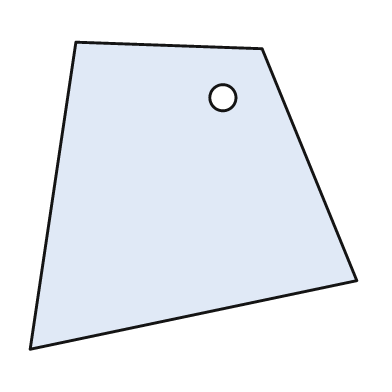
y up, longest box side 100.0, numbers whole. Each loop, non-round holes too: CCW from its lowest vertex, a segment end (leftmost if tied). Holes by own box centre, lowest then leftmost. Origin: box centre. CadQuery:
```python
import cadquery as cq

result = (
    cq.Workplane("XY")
    .moveTo(-50.0, -47.0)
    .lineTo(50.0, -26.0)
    .lineTo(21.0, 45.0)
    .lineTo(-36.0, 47.0)
    .close()
    .moveTo(9.0, 30.0)
    .circle(4.0)
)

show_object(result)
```